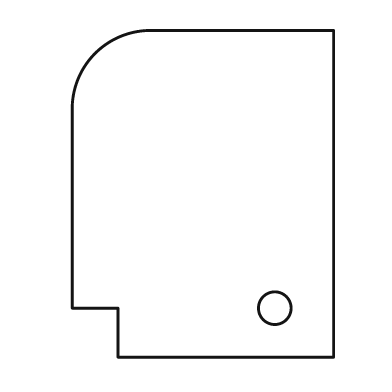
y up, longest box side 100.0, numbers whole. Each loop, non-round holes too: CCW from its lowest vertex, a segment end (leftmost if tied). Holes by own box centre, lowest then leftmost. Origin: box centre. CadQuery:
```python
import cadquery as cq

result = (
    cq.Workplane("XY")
    .moveTo(-26.0, -50.0)
    .lineTo(40.0, -50.0)
    .lineTo(40.0, 50.0)
    .lineTo(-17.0, 50.0)
    .threePointArc((-33.0, 43.0), (-40.0, 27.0))
    .lineTo(-40.0, -35.0)
    .lineTo(-26.0, -35.0)
    .close()
    .moveTo(22.0, -35.0)
    .circle(5.0)
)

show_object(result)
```